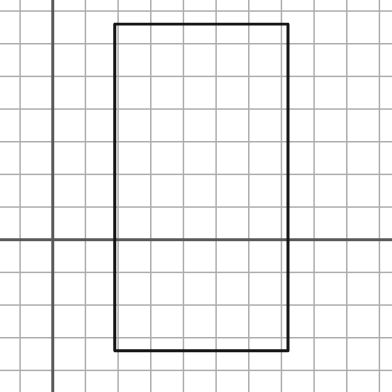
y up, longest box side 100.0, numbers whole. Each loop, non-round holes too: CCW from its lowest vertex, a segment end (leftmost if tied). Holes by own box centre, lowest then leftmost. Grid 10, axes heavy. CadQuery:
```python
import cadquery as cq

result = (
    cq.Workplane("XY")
    .moveTo(19.0, -34.0)
    .lineTo(72.0, -34.0)
    .lineTo(72.0, 66.0)
    .lineTo(19.0, 66.0)
    .close()
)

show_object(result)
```